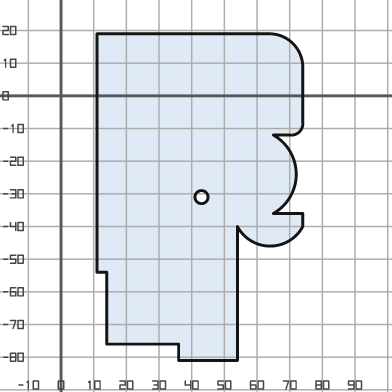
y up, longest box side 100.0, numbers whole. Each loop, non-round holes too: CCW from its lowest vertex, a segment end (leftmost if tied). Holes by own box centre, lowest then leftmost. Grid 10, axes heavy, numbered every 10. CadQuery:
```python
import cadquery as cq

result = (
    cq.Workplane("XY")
    .moveTo(36.0, -81.0)
    .lineTo(54.0, -81.0)
    .lineTo(54.0, -40.0)
    .threePointArc((64.0, -46.0), (74.0, -40.0))
    .lineTo(74.0, -36.0)
    .lineTo(65.0, -36.0)
    .threePointArc((72.0, -24.0), (65.0, -12.0))
    .lineTo(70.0, -12.0)
    .threePointArc((73.0, -11.0), (74.0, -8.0))
    .lineTo(74.0, 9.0)
    .threePointArc((71.0, 16.0), (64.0, 19.0))
    .lineTo(11.0, 19.0)
    .lineTo(11.0, -54.0)
    .lineTo(14.0, -54.0)
    .lineTo(14.0, -76.0)
    .lineTo(36.0, -76.0)
    .close()
    .moveTo(43.0, -31.0)
    .circle(2.0)
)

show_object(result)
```